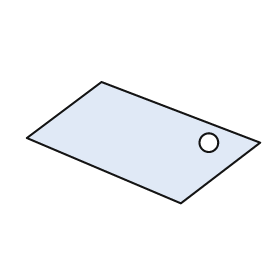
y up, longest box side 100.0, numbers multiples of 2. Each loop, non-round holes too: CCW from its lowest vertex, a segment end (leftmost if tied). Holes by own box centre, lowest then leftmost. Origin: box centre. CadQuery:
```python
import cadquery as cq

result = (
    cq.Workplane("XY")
    .moveTo(16.0, -26.0)
    .lineTo(50.0, 0.0)
    .lineTo(-18.0, 26.0)
    .lineTo(-50.0, 2.0)
    .close()
    .moveTo(28.0, 0.0)
    .circle(4.0)
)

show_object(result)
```